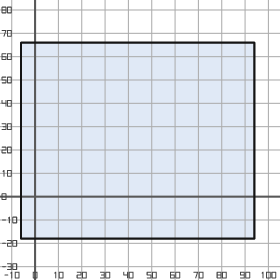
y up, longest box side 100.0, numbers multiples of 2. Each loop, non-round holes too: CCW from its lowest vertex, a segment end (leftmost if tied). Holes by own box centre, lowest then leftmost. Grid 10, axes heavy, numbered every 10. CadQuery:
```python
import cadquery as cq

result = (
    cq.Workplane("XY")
    .moveTo(-6.0, -18.0)
    .lineTo(94.0, -18.0)
    .lineTo(94.0, 66.0)
    .lineTo(-6.0, 66.0)
    .close()
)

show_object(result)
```